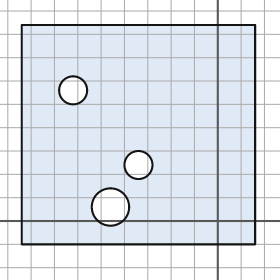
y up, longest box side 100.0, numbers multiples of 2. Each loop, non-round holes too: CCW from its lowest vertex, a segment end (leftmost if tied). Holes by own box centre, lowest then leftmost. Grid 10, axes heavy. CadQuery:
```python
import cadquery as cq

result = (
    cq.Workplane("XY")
    .moveTo(-84.0, -10.0)
    .lineTo(16.0, -10.0)
    .lineTo(16.0, 84.0)
    .lineTo(-84.0, 84.0)
    .close()
    .moveTo(-46.0, 6.0)
    .circle(8.0)
    .moveTo(-34.0, 24.0)
    .circle(6.0)
    .moveTo(-62.0, 56.0)
    .circle(6.0)
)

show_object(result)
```